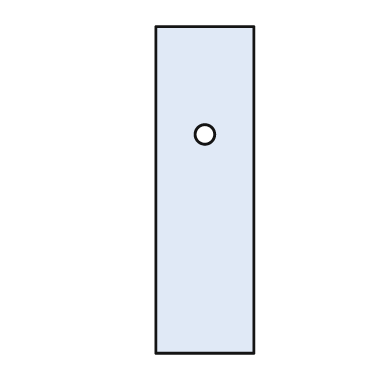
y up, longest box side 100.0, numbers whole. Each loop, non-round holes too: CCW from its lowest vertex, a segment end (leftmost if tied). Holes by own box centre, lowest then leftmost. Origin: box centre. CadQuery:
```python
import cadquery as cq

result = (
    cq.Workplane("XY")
    .moveTo(-15.0, -50.0)
    .lineTo(15.0, -50.0)
    .lineTo(15.0, 50.0)
    .lineTo(-15.0, 50.0)
    .close()
    .moveTo(0.0, 17.0)
    .circle(3.0)
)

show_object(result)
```